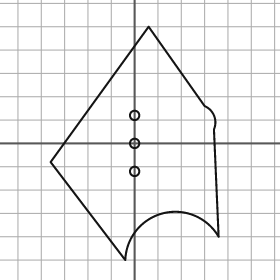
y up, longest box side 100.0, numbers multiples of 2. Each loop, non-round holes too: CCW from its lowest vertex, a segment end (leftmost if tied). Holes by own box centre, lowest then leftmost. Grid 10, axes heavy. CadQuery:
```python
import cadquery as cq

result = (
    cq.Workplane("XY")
    .moveTo(-4.0, -50.0)
    .threePointArc((12.0, -30.0), (36.0, -40.0))
    .lineTo(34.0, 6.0)
    .threePointArc((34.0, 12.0), (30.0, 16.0))
    .lineTo(6.0, 50.0)
    .lineTo(-36.0, -8.0)
    .close()
    .moveTo(0.0, -12.0)
    .circle(2.0)
    .moveTo(0.0, 0.0)
    .circle(2.0)
    .moveTo(0.0, 12.0)
    .circle(2.0)
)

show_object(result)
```